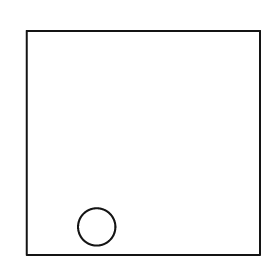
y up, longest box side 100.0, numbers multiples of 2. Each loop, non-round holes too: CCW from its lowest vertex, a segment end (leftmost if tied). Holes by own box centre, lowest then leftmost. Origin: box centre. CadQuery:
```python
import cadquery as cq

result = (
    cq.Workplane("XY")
    .moveTo(-50.0, -48.0)
    .lineTo(50.0, -48.0)
    .lineTo(50.0, 48.0)
    .lineTo(-50.0, 48.0)
    .close()
    .moveTo(-20.0, -36.0)
    .circle(8.0)
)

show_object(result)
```